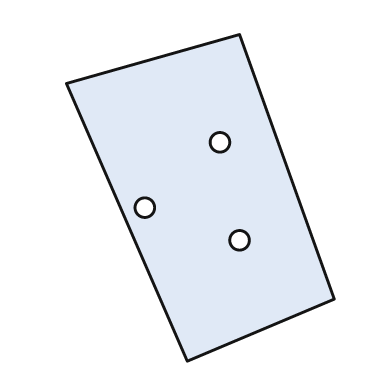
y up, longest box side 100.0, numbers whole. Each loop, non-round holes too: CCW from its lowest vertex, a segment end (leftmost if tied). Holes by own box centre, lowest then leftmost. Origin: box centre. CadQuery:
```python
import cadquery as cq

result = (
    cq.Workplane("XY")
    .moveTo(-4.0, -50.0)
    .lineTo(41.0, -31.0)
    .lineTo(12.0, 50.0)
    .lineTo(-41.0, 35.0)
    .close()
    .moveTo(12.0, -13.0)
    .circle(3.0)
    .moveTo(-17.0, -3.0)
    .circle(3.0)
    .moveTo(6.0, 17.0)
    .circle(3.0)
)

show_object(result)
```